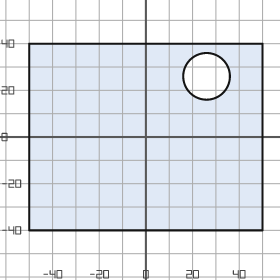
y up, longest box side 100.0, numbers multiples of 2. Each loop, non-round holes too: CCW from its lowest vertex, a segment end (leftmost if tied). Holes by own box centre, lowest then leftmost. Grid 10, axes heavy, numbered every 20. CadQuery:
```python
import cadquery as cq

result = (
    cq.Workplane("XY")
    .moveTo(-50.0, -40.0)
    .lineTo(50.0, -40.0)
    .lineTo(50.0, 40.0)
    .lineTo(-50.0, 40.0)
    .close()
    .moveTo(26.0, 26.0)
    .circle(10.0)
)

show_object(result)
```